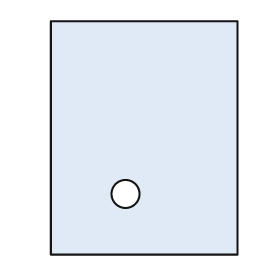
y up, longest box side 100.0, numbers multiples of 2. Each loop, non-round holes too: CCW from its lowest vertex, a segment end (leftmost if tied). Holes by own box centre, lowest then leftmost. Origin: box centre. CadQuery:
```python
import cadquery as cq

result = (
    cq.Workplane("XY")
    .moveTo(-40.0, -50.0)
    .lineTo(40.0, -50.0)
    .lineTo(40.0, 50.0)
    .lineTo(-40.0, 50.0)
    .close()
    .moveTo(-8.0, -24.0)
    .circle(6.0)
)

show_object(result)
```